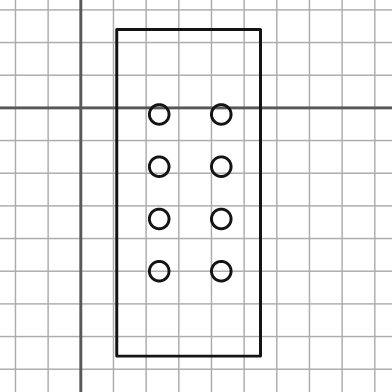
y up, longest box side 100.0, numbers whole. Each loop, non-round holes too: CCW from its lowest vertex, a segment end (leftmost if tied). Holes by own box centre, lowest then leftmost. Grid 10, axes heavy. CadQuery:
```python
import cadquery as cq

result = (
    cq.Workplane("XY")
    .moveTo(11.0, -76.0)
    .lineTo(55.0, -76.0)
    .lineTo(55.0, 24.0)
    .lineTo(11.0, 24.0)
    .close()
    .moveTo(24.0, -50.0)
    .circle(3.0)
    .moveTo(43.0, -50.0)
    .circle(3.0)
    .moveTo(24.0, -34.0)
    .circle(3.0)
    .moveTo(43.0, -34.0)
    .circle(3.0)
    .moveTo(24.0, -18.0)
    .circle(3.0)
    .moveTo(43.0, -18.0)
    .circle(3.0)
    .moveTo(24.0, -2.0)
    .circle(3.0)
    .moveTo(43.0, -2.0)
    .circle(3.0)
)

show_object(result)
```